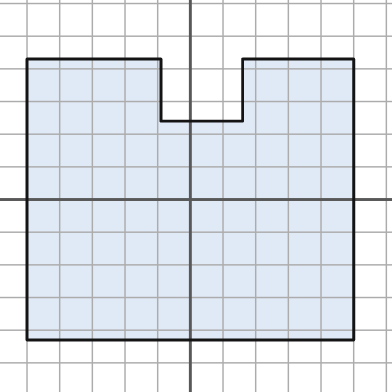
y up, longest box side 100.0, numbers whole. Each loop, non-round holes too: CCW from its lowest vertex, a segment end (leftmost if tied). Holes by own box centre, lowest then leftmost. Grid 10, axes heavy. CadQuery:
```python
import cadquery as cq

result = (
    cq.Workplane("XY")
    .moveTo(-50.0, -43.0)
    .lineTo(50.0, -43.0)
    .lineTo(50.0, 43.0)
    .lineTo(16.0, 43.0)
    .lineTo(16.0, 24.0)
    .lineTo(-9.0, 24.0)
    .lineTo(-9.0, 43.0)
    .lineTo(-50.0, 43.0)
    .close()
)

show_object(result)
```